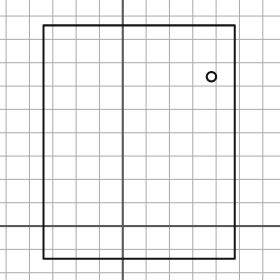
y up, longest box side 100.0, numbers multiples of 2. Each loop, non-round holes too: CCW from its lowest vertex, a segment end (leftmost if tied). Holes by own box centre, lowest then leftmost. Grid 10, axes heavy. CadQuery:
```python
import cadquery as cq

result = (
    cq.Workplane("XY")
    .moveTo(-34.0, -14.0)
    .lineTo(48.0, -14.0)
    .lineTo(48.0, 86.0)
    .lineTo(-34.0, 86.0)
    .close()
    .moveTo(38.0, 64.0)
    .circle(2.0)
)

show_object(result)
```